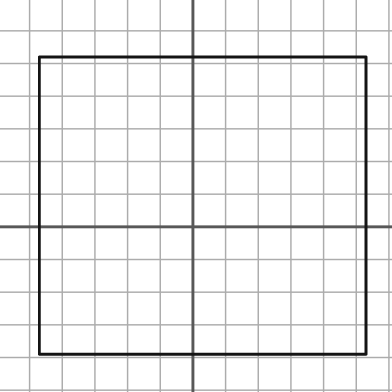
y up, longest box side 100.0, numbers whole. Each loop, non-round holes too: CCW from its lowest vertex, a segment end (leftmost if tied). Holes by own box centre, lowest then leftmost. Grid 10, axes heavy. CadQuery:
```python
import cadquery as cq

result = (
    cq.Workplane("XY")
    .moveTo(-47.0, -39.0)
    .lineTo(53.0, -39.0)
    .lineTo(53.0, 52.0)
    .lineTo(-47.0, 52.0)
    .close()
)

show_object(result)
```